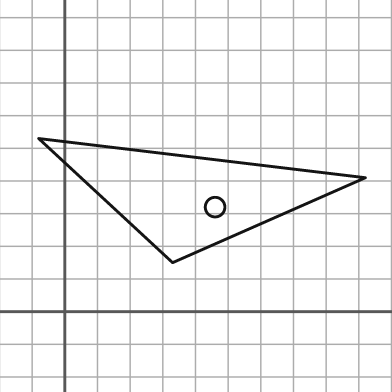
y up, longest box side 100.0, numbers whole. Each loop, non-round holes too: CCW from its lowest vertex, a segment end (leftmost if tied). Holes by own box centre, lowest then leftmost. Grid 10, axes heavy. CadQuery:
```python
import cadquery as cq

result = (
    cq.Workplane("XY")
    .moveTo(33.0, 15.0)
    .lineTo(92.0, 41.0)
    .lineTo(-8.0, 53.0)
    .close()
    .moveTo(46.0, 32.0)
    .circle(3.0)
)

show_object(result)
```